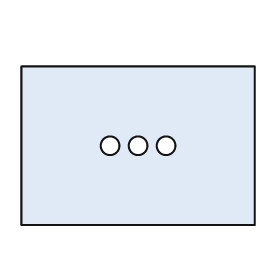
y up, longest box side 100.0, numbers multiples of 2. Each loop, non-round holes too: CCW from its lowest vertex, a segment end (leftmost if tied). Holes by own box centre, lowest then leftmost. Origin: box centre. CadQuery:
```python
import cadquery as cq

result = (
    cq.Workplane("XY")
    .moveTo(-50.0, -34.0)
    .lineTo(50.0, -34.0)
    .lineTo(50.0, 34.0)
    .lineTo(-50.0, 34.0)
    .close()
    .moveTo(-12.0, 0.0)
    .circle(4.0)
    .moveTo(0.0, 0.0)
    .circle(4.0)
    .moveTo(12.0, 0.0)
    .circle(4.0)
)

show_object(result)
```